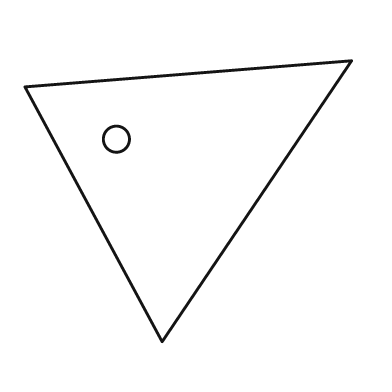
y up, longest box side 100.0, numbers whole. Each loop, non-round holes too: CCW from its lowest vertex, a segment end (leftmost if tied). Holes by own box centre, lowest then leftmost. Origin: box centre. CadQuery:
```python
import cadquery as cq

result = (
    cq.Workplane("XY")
    .moveTo(-8.0, -43.0)
    .lineTo(50.0, 43.0)
    .lineTo(-50.0, 35.0)
    .close()
    .moveTo(-22.0, 19.0)
    .circle(4.0)
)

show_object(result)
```